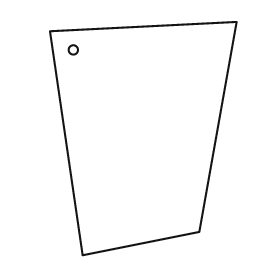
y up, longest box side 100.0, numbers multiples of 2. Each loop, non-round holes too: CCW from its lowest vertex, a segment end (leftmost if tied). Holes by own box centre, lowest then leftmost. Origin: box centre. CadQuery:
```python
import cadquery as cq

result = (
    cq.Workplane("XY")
    .moveTo(-26.0, -50.0)
    .lineTo(24.0, -40.0)
    .lineTo(40.0, 50.0)
    .lineTo(-40.0, 46.0)
    .close()
    .moveTo(-30.0, 38.0)
    .circle(2.0)
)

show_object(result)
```